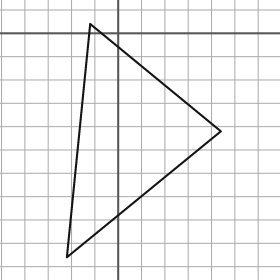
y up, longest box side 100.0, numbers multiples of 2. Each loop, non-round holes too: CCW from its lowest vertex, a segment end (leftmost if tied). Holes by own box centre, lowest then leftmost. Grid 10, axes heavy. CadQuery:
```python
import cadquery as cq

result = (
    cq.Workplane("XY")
    .moveTo(-22.0, -96.0)
    .lineTo(44.0, -42.0)
    .lineTo(-12.0, 4.0)
    .close()
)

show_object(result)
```